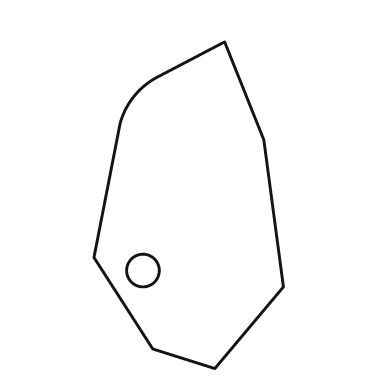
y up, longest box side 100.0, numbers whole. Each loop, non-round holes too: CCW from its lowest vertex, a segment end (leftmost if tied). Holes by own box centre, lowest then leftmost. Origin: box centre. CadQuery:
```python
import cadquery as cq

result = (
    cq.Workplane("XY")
    .moveTo(8.0, -50.0)
    .lineTo(29.0, -25.0)
    .lineTo(23.0, 20.0)
    .lineTo(11.0, 50.0)
    .lineTo(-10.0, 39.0)
    .threePointArc((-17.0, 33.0), (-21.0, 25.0))
    .lineTo(-29.0, -16.0)
    .lineTo(-11.0, -44.0)
    .close()
    .moveTo(-14.0, -20.0)
    .circle(5.0)
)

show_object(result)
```